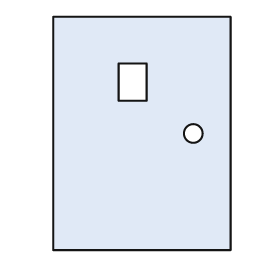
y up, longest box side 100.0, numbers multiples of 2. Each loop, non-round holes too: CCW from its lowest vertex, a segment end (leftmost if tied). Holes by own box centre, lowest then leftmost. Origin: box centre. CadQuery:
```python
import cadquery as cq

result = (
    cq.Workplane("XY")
    .moveTo(-38.0, -50.0)
    .lineTo(38.0, -50.0)
    .lineTo(38.0, 50.0)
    .lineTo(-38.0, 50.0)
    .close()
    .moveTo(22.0, 0.0)
    .circle(4.0)
    .moveTo(-10.0, 14.0)
    .lineTo(2.0, 14.0)
    .lineTo(2.0, 30.0)
    .lineTo(-10.0, 30.0)
    .close()
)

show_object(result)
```